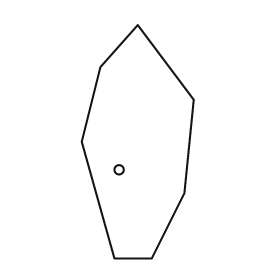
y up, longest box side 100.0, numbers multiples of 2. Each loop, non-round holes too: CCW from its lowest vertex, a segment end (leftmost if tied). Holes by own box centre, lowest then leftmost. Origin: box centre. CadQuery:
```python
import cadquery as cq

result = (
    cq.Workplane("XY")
    .moveTo(-10.0, -50.0)
    .lineTo(6.0, -50.0)
    .lineTo(20.0, -22.0)
    .lineTo(24.0, 18.0)
    .lineTo(0.0, 50.0)
    .lineTo(-16.0, 32.0)
    .lineTo(-24.0, 0.0)
    .close()
    .moveTo(-8.0, -12.0)
    .circle(2.0)
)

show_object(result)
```